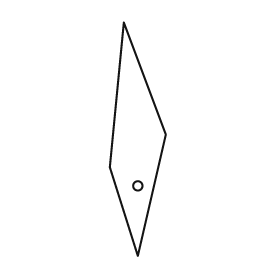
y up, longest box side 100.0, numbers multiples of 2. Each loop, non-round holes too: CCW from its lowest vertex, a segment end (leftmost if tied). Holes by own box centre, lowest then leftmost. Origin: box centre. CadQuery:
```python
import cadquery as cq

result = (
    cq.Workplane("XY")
    .moveTo(0.0, -50.0)
    .lineTo(12.0, 2.0)
    .lineTo(-6.0, 50.0)
    .lineTo(-12.0, -12.0)
    .close()
    .moveTo(0.0, -20.0)
    .circle(2.0)
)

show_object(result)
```